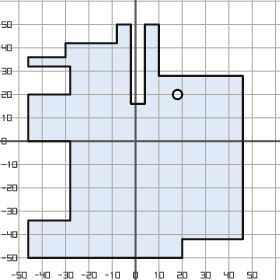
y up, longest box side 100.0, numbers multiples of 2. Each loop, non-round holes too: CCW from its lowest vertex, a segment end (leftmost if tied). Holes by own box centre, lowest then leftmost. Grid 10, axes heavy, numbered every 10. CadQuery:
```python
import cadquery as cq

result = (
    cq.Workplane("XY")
    .moveTo(-46.0, -50.0)
    .lineTo(20.0, -50.0)
    .lineTo(20.0, -42.0)
    .lineTo(46.0, -42.0)
    .lineTo(46.0, 28.0)
    .lineTo(10.0, 28.0)
    .lineTo(10.0, 50.0)
    .lineTo(4.0, 50.0)
    .lineTo(4.0, 16.0)
    .lineTo(-2.0, 16.0)
    .lineTo(-2.0, 50.0)
    .lineTo(-8.0, 50.0)
    .lineTo(-8.0, 42.0)
    .lineTo(-30.0, 42.0)
    .lineTo(-30.0, 36.0)
    .lineTo(-46.0, 36.0)
    .lineTo(-46.0, 32.0)
    .lineTo(-28.0, 32.0)
    .lineTo(-28.0, 20.0)
    .lineTo(-46.0, 20.0)
    .lineTo(-46.0, 0.0)
    .lineTo(-28.0, 0.0)
    .lineTo(-28.0, -34.0)
    .lineTo(-46.0, -34.0)
    .close()
    .moveTo(18.0, 20.0)
    .circle(2.0)
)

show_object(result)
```